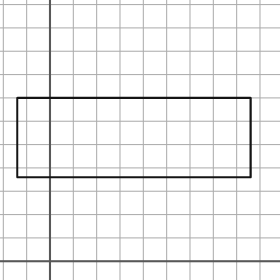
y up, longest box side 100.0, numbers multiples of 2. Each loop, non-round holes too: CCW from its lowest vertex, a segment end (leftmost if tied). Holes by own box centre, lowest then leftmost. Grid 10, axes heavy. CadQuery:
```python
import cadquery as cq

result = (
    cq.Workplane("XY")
    .moveTo(-14.0, 36.0)
    .lineTo(86.0, 36.0)
    .lineTo(86.0, 70.0)
    .lineTo(-14.0, 70.0)
    .close()
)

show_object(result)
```